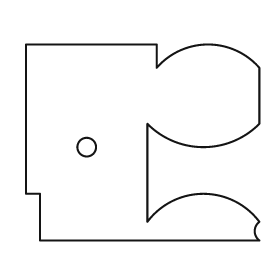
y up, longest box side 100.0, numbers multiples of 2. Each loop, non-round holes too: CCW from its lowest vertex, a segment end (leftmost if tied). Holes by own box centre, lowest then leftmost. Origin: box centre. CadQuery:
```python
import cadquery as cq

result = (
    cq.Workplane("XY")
    .moveTo(-44.0, -42.0)
    .lineTo(50.0, -42.0)
    .threePointArc((48.0, -38.0), (50.0, -34.0))
    .threePointArc((26.0, -22.0), (2.0, -34.0))
    .lineTo(2.0, 8.0)
    .threePointArc((26.0, -2.0), (50.0, 8.0))
    .lineTo(50.0, 32.0)
    .threePointArc((28.0, 42.0), (6.0, 32.0))
    .lineTo(6.0, 42.0)
    .lineTo(-50.0, 42.0)
    .lineTo(-50.0, -22.0)
    .lineTo(-44.0, -22.0)
    .close()
    .moveTo(-24.0, -2.0)
    .circle(4.0)
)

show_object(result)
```